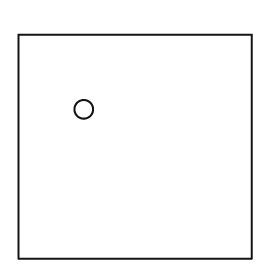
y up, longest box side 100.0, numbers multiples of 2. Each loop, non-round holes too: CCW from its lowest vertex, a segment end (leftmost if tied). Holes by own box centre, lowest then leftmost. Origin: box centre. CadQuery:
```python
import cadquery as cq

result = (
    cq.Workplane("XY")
    .moveTo(-50.0, -48.0)
    .lineTo(50.0, -48.0)
    .lineTo(50.0, 48.0)
    .lineTo(-50.0, 48.0)
    .close()
    .moveTo(-22.0, 16.0)
    .circle(4.0)
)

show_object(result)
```